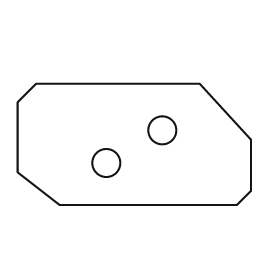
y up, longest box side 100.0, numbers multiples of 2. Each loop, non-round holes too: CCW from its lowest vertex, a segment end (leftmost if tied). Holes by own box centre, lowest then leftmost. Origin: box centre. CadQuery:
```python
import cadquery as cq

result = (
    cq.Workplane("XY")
    .moveTo(-32.0, -26.0)
    .lineTo(44.0, -26.0)
    .lineTo(50.0, -20.0)
    .lineTo(50.0, 2.0)
    .lineTo(28.0, 26.0)
    .lineTo(-42.0, 26.0)
    .lineTo(-50.0, 18.0)
    .lineTo(-50.0, -12.0)
    .close()
    .moveTo(-12.0, -8.0)
    .circle(6.0)
    .moveTo(12.0, 6.0)
    .circle(6.0)
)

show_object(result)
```